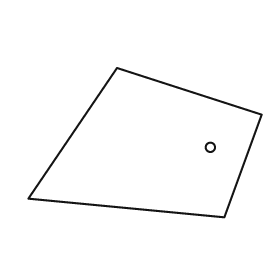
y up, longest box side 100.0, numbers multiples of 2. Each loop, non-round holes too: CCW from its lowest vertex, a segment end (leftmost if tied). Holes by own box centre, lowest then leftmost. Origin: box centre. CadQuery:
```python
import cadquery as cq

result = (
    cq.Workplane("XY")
    .moveTo(34.0, -32.0)
    .lineTo(50.0, 12.0)
    .lineTo(-12.0, 32.0)
    .lineTo(-50.0, -24.0)
    .close()
    .moveTo(28.0, -2.0)
    .circle(2.0)
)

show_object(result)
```